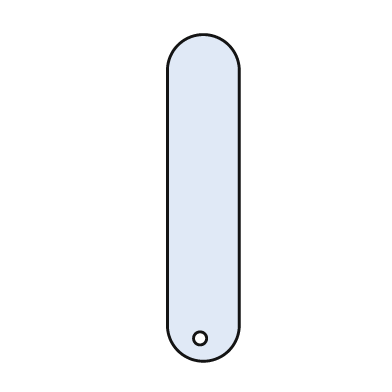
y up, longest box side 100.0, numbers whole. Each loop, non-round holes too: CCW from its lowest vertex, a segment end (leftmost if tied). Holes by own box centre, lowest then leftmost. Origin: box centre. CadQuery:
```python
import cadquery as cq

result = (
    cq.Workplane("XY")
    .moveTo(-11.0, -39.0)
    .threePointArc((0.0, -50.0), (11.0, -39.0))
    .lineTo(11.0, 39.0)
    .threePointArc((0.0, 50.0), (-11.0, 39.0))
    .close()
    .moveTo(-1.0, -43.0)
    .circle(2.0)
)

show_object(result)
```